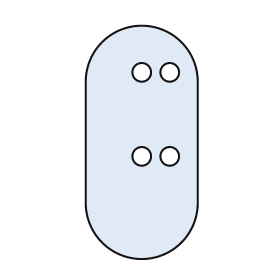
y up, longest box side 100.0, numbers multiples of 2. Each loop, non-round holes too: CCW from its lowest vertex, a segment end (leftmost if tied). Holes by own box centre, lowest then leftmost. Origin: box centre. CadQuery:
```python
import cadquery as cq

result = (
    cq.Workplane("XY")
    .moveTo(-24.0, -26.0)
    .threePointArc((0.0, -50.0), (24.0, -26.0))
    .lineTo(24.0, 26.0)
    .threePointArc((0.0, 50.0), (-24.0, 26.0))
    .close()
    .moveTo(0.0, -6.0)
    .circle(4.0)
    .moveTo(12.0, -6.0)
    .circle(4.0)
    .moveTo(0.0, 30.0)
    .circle(4.0)
    .moveTo(12.0, 30.0)
    .circle(4.0)
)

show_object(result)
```